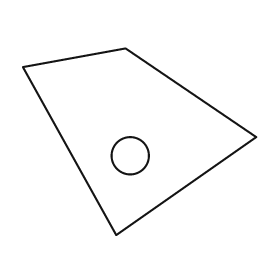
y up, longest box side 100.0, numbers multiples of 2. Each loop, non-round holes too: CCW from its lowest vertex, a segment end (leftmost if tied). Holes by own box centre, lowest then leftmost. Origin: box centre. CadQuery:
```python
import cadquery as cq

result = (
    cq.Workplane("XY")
    .moveTo(-10.0, -40.0)
    .lineTo(50.0, 2.0)
    .lineTo(-6.0, 40.0)
    .lineTo(-50.0, 32.0)
    .close()
    .moveTo(-4.0, -6.0)
    .circle(8.0)
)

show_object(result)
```